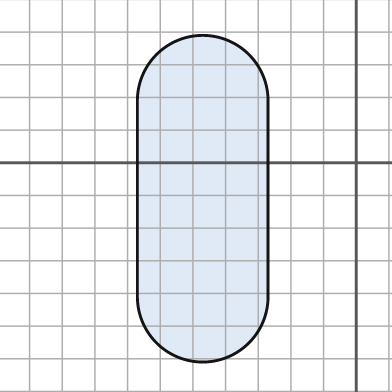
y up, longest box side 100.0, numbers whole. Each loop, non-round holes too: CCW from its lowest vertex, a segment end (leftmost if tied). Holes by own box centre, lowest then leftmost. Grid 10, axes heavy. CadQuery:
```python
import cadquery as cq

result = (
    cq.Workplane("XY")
    .moveTo(-67.0, -41.0)
    .threePointArc((-47.0, -61.0), (-27.0, -41.0))
    .lineTo(-27.0, 19.0)
    .threePointArc((-47.0, 39.0), (-67.0, 19.0))
    .close()
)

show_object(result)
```